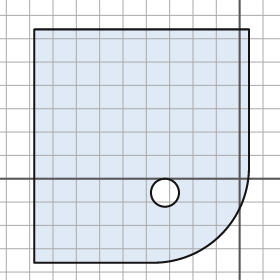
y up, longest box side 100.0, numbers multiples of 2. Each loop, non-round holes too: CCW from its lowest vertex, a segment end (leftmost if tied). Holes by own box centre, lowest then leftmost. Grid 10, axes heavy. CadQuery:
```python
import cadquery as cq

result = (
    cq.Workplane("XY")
    .moveTo(-88.0, -36.0)
    .lineTo(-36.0, -36.0)
    .threePointArc((-8.0, -24.0), (4.0, 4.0))
    .lineTo(4.0, 64.0)
    .lineTo(-88.0, 64.0)
    .close()
    .moveTo(-32.0, -6.0)
    .circle(6.0)
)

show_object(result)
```